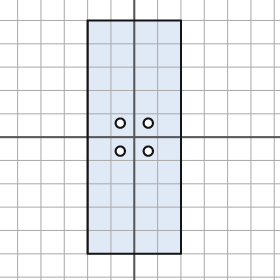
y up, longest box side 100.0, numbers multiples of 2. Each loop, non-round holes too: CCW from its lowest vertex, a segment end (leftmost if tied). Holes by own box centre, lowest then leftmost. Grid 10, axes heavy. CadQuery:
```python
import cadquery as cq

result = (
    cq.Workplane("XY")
    .moveTo(-20.0, -50.0)
    .lineTo(20.0, -50.0)
    .lineTo(20.0, 50.0)
    .lineTo(-20.0, 50.0)
    .close()
    .moveTo(-6.0, -6.0)
    .circle(2.0)
    .moveTo(6.0, -6.0)
    .circle(2.0)
    .moveTo(-6.0, 6.0)
    .circle(2.0)
    .moveTo(6.0, 6.0)
    .circle(2.0)
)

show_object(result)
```